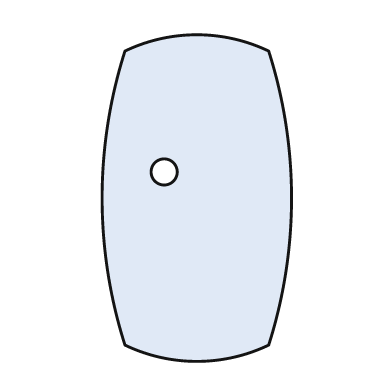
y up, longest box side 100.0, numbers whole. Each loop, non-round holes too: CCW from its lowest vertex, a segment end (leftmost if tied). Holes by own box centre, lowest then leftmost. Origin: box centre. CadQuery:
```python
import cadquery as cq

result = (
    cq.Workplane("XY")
    .moveTo(-22.0, -45.0)
    .threePointArc((0.0, -50.0), (22.0, -45.0))
    .threePointArc((29.0, 0.0), (22.0, 45.0))
    .threePointArc((0.0, 50.0), (-22.0, 45.0))
    .threePointArc((-29.0, 0.0), (-22.0, -45.0))
    .close()
    .moveTo(-10.0, 8.0)
    .circle(4.0)
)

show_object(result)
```